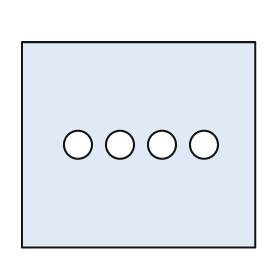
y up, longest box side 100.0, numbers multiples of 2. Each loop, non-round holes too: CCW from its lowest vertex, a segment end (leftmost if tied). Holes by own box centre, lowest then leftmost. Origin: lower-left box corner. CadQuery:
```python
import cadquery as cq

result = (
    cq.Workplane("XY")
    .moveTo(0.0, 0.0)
    .lineTo(100.0, 0.0)
    .lineTo(100.0, 88.0)
    .lineTo(0.0, 88.0)
    .close()
    .moveTo(24.0, 44.0)
    .circle(6.0)
    .moveTo(42.0, 44.0)
    .circle(6.0)
    .moveTo(60.0, 44.0)
    .circle(6.0)
    .moveTo(78.0, 44.0)
    .circle(6.0)
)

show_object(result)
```